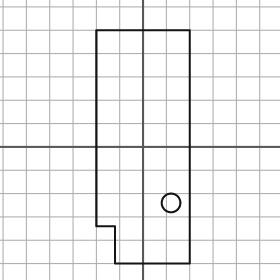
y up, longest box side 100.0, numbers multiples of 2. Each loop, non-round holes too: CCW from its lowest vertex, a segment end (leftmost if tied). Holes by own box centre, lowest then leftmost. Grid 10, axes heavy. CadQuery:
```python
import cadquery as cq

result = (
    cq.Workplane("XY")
    .moveTo(-12.0, -50.0)
    .lineTo(20.0, -50.0)
    .lineTo(20.0, 50.0)
    .lineTo(-20.0, 50.0)
    .lineTo(-20.0, -34.0)
    .lineTo(-12.0, -34.0)
    .close()
    .moveTo(12.0, -24.0)
    .circle(4.0)
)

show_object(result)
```